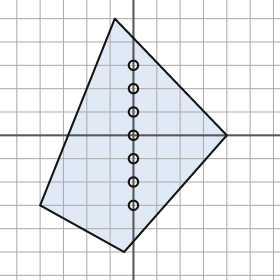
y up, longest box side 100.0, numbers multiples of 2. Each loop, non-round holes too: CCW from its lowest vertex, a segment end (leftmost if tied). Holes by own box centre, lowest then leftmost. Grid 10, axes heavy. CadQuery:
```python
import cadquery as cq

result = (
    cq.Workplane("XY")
    .moveTo(-4.0, -50.0)
    .lineTo(40.0, 0.0)
    .lineTo(-8.0, 50.0)
    .lineTo(-40.0, -30.0)
    .close()
    .moveTo(0.0, -30.0)
    .circle(2.0)
    .moveTo(0.0, -20.0)
    .circle(2.0)
    .moveTo(0.0, -10.0)
    .circle(2.0)
    .moveTo(0.0, 0.0)
    .circle(2.0)
    .moveTo(0.0, 10.0)
    .circle(2.0)
    .moveTo(0.0, 20.0)
    .circle(2.0)
    .moveTo(0.0, 30.0)
    .circle(2.0)
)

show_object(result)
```